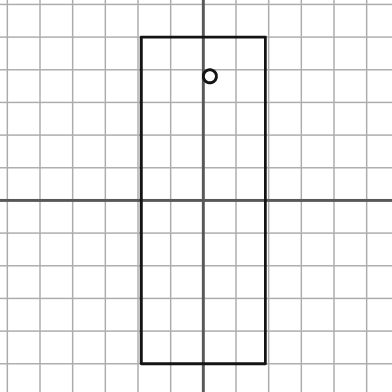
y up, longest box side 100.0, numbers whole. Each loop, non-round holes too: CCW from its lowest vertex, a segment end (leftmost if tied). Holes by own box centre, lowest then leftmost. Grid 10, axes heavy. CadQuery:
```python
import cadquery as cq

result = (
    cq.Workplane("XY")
    .moveTo(-19.0, -50.0)
    .lineTo(19.0, -50.0)
    .lineTo(19.0, 50.0)
    .lineTo(-19.0, 50.0)
    .close()
    .moveTo(2.0, 38.0)
    .circle(2.0)
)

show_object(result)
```